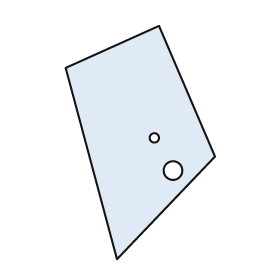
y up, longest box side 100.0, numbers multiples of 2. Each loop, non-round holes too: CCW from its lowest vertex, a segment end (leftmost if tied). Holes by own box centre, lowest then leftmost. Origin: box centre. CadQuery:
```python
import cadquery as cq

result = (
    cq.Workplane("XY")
    .moveTo(-10.0, -50.0)
    .lineTo(32.0, -6.0)
    .lineTo(8.0, 50.0)
    .lineTo(-32.0, 32.0)
    .close()
    .moveTo(14.0, -12.0)
    .circle(4.0)
    .moveTo(6.0, 2.0)
    .circle(2.0)
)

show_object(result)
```